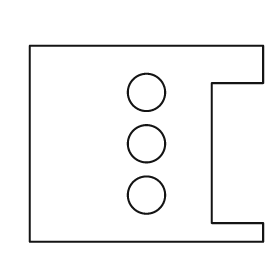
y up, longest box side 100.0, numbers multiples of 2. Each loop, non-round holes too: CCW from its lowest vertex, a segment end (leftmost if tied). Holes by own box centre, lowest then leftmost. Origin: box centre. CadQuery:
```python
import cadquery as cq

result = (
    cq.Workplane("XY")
    .moveTo(-50.0, -42.0)
    .lineTo(50.0, -42.0)
    .lineTo(50.0, -34.0)
    .lineTo(28.0, -34.0)
    .lineTo(28.0, 26.0)
    .lineTo(50.0, 26.0)
    .lineTo(50.0, 42.0)
    .lineTo(-50.0, 42.0)
    .close()
    .moveTo(0.0, -22.0)
    .circle(8.0)
    .moveTo(0.0, 0.0)
    .circle(8.0)
    .moveTo(0.0, 22.0)
    .circle(8.0)
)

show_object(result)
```